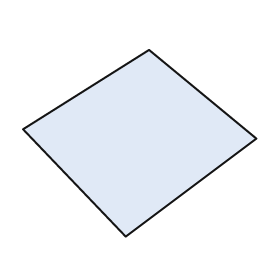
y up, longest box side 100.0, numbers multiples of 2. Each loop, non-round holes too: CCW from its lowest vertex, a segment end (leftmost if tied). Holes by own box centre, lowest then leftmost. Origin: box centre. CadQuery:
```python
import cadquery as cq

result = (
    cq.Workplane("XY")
    .moveTo(-6.0, -40.0)
    .lineTo(50.0, 2.0)
    .lineTo(4.0, 40.0)
    .lineTo(-50.0, 6.0)
    .close()
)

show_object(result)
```